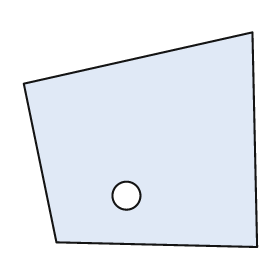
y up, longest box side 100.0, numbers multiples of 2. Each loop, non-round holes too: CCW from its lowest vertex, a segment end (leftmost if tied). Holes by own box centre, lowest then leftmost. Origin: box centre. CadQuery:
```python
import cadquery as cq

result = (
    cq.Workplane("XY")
    .moveTo(50.0, -46.0)
    .lineTo(48.0, 46.0)
    .lineTo(-50.0, 24.0)
    .lineTo(-36.0, -44.0)
    .close()
    .moveTo(-6.0, -24.0)
    .circle(6.0)
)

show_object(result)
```